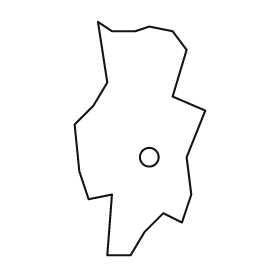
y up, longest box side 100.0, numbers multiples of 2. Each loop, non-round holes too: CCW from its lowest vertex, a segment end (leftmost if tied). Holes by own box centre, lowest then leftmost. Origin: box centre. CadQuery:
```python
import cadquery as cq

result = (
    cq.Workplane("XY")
    .moveTo(-14.0, -50.0)
    .lineTo(-4.0, -50.0)
    .lineTo(2.0, -40.0)
    .lineTo(10.0, -32.0)
    .lineTo(18.0, -36.0)
    .lineTo(22.0, -24.0)
    .lineTo(20.0, -8.0)
    .lineTo(28.0, 12.0)
    .lineTo(14.0, 18.0)
    .lineTo(20.0, 38.0)
    .lineTo(14.0, 46.0)
    .lineTo(4.0, 48.0)
    .lineTo(-2.0, 46.0)
    .lineTo(-12.0, 46.0)
    .lineTo(-18.0, 50.0)
    .lineTo(-14.0, 24.0)
    .lineTo(-20.0, 14.0)
    .lineTo(-28.0, 6.0)
    .lineTo(-26.0, -14.0)
    .lineTo(-22.0, -26.0)
    .lineTo(-12.0, -24.0)
    .close()
    .moveTo(4.0, -8.0)
    .circle(4.0)
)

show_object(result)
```